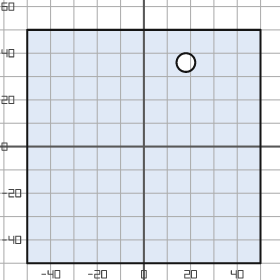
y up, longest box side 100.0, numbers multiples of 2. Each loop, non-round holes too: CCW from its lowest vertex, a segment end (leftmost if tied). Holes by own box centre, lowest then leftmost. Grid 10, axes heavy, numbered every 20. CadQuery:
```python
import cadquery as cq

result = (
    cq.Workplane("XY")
    .moveTo(-50.0, -50.0)
    .lineTo(50.0, -50.0)
    .lineTo(50.0, 50.0)
    .lineTo(-50.0, 50.0)
    .close()
    .moveTo(18.0, 36.0)
    .circle(4.0)
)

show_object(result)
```